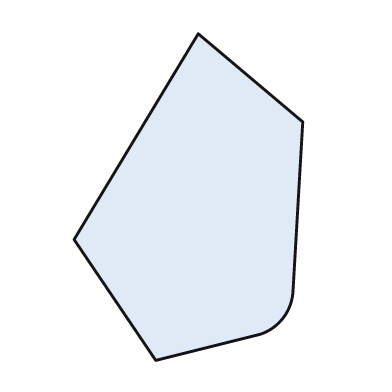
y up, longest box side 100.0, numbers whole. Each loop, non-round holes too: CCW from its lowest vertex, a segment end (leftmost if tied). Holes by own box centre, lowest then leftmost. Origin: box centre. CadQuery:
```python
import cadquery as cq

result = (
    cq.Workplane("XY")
    .moveTo(-10.0, -50.0)
    .lineTo(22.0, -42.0)
    .threePointArc((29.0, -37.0), (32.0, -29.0))
    .lineTo(35.0, 23.0)
    .lineTo(3.0, 50.0)
    .lineTo(-35.0, -13.0)
    .close()
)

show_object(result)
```